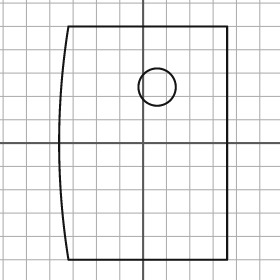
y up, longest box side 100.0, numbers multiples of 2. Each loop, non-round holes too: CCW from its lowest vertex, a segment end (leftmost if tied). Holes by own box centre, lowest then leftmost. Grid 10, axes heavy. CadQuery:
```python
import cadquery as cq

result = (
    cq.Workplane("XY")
    .moveTo(-32.0, -50.0)
    .lineTo(36.0, -50.0)
    .lineTo(36.0, 50.0)
    .lineTo(-32.0, 50.0)
    .threePointArc((-36.0, 0.0), (-32.0, -50.0))
    .close()
    .moveTo(6.0, 24.0)
    .circle(8.0)
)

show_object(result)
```